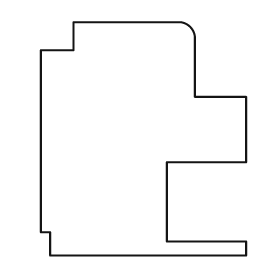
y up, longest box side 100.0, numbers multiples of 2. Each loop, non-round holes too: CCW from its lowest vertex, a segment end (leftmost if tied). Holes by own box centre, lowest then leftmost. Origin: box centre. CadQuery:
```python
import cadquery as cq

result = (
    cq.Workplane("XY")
    .moveTo(-40.0, -50.0)
    .lineTo(44.0, -50.0)
    .lineTo(44.0, -44.0)
    .lineTo(10.0, -44.0)
    .lineTo(10.0, -10.0)
    .lineTo(44.0, -10.0)
    .lineTo(44.0, 18.0)
    .lineTo(22.0, 18.0)
    .lineTo(22.0, 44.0)
    .threePointArc((20.0, 48.0), (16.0, 50.0))
    .lineTo(-30.0, 50.0)
    .lineTo(-30.0, 38.0)
    .lineTo(-44.0, 38.0)
    .lineTo(-44.0, -40.0)
    .lineTo(-40.0, -40.0)
    .close()
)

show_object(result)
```